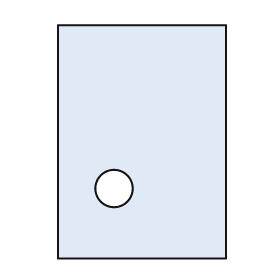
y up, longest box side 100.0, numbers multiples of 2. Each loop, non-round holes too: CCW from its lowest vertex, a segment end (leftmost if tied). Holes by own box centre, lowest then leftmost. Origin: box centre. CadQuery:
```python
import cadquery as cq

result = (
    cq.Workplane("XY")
    .moveTo(-36.0, -50.0)
    .lineTo(36.0, -50.0)
    .lineTo(36.0, 50.0)
    .lineTo(-36.0, 50.0)
    .close()
    .moveTo(-12.0, -20.0)
    .circle(8.0)
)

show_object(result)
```